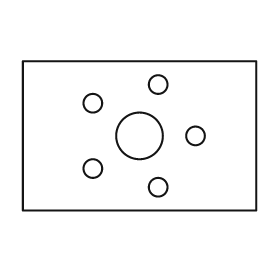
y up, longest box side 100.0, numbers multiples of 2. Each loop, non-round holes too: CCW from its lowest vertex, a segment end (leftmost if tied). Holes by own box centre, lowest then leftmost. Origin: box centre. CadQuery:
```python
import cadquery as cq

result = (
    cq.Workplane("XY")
    .moveTo(-50.0, -32.0)
    .lineTo(50.0, -32.0)
    .lineTo(50.0, 32.0)
    .lineTo(-50.0, 32.0)
    .close()
    .moveTo(8.0, -22.0)
    .circle(4.0)
    .moveTo(-20.0, -14.0)
    .circle(4.0)
    .moveTo(0.0, 0.0)
    .circle(10.0)
    .moveTo(24.0, 0.0)
    .circle(4.0)
    .moveTo(-20.0, 14.0)
    .circle(4.0)
    .moveTo(8.0, 22.0)
    .circle(4.0)
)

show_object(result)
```